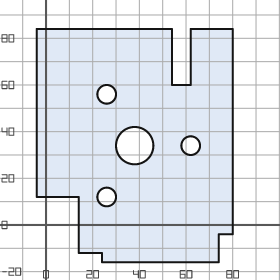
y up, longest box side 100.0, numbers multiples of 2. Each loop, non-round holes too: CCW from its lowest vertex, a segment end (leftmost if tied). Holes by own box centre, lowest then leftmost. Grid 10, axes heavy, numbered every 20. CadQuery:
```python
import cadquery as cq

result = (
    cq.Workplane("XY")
    .moveTo(24.0, -16.0)
    .lineTo(74.0, -16.0)
    .lineTo(74.0, -4.0)
    .lineTo(80.0, -4.0)
    .lineTo(80.0, 84.0)
    .lineTo(62.0, 84.0)
    .lineTo(62.0, 60.0)
    .lineTo(54.0, 60.0)
    .lineTo(54.0, 84.0)
    .lineTo(-4.0, 84.0)
    .lineTo(-4.0, 12.0)
    .lineTo(14.0, 12.0)
    .lineTo(14.0, -12.0)
    .lineTo(24.0, -12.0)
    .close()
    .moveTo(26.0, 12.0)
    .circle(4.0)
    .moveTo(38.0, 34.0)
    .circle(8.0)
    .moveTo(62.0, 34.0)
    .circle(4.0)
    .moveTo(26.0, 56.0)
    .circle(4.0)
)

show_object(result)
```